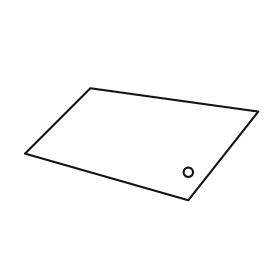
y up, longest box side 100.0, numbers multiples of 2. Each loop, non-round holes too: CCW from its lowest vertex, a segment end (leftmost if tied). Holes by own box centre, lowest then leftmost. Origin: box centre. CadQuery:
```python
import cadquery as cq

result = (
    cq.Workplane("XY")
    .moveTo(20.0, -24.0)
    .lineTo(50.0, 14.0)
    .lineTo(-22.0, 24.0)
    .lineTo(-50.0, -4.0)
    .close()
    .moveTo(20.0, -12.0)
    .circle(2.0)
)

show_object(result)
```